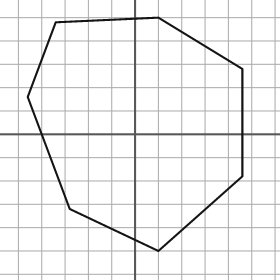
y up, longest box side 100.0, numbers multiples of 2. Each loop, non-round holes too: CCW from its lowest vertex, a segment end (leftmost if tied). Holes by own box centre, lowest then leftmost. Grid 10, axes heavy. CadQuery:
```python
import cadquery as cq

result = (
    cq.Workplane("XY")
    .moveTo(10.0, -50.0)
    .lineTo(46.0, -18.0)
    .lineTo(46.0, 28.0)
    .lineTo(10.0, 50.0)
    .lineTo(-34.0, 48.0)
    .lineTo(-46.0, 16.0)
    .lineTo(-28.0, -32.0)
    .close()
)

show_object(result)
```